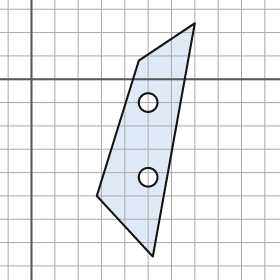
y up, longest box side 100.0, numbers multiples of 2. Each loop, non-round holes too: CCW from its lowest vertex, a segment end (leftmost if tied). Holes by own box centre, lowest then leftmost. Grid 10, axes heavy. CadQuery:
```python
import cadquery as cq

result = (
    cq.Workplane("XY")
    .moveTo(52.0, -76.0)
    .lineTo(70.0, 24.0)
    .lineTo(46.0, 8.0)
    .lineTo(28.0, -50.0)
    .close()
    .moveTo(50.0, -42.0)
    .circle(4.0)
    .moveTo(50.0, -10.0)
    .circle(4.0)
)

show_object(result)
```